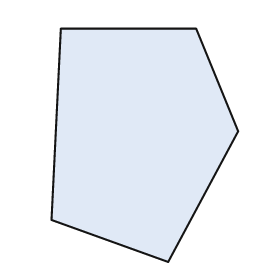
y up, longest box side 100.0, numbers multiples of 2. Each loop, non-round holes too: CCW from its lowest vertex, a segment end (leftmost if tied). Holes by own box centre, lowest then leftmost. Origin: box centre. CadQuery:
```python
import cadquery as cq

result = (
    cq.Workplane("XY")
    .moveTo(10.0, -50.0)
    .lineTo(40.0, 6.0)
    .lineTo(22.0, 50.0)
    .lineTo(-36.0, 50.0)
    .lineTo(-40.0, -32.0)
    .close()
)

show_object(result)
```